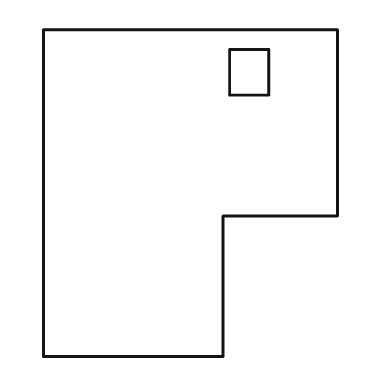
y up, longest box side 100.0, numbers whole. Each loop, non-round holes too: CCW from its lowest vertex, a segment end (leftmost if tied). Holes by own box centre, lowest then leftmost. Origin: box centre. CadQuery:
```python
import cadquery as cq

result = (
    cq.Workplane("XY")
    .moveTo(-45.0, -50.0)
    .lineTo(10.0, -50.0)
    .lineTo(10.0, -7.0)
    .lineTo(45.0, -7.0)
    .lineTo(45.0, 50.0)
    .lineTo(-45.0, 50.0)
    .close()
    .moveTo(12.0, 30.0)
    .lineTo(24.0, 30.0)
    .lineTo(24.0, 44.0)
    .lineTo(12.0, 44.0)
    .close()
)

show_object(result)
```